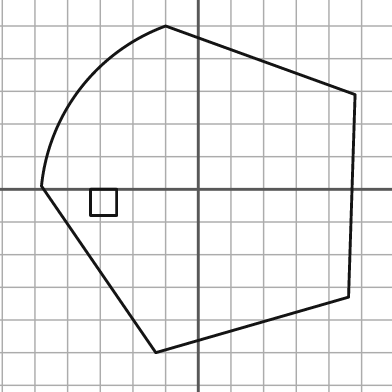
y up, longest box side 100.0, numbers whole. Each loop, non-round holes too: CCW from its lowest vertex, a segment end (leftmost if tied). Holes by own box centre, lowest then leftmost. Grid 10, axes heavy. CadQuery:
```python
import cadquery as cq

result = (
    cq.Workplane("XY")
    .moveTo(-13.0, -50.0)
    .lineTo(46.0, -33.0)
    .lineTo(48.0, 29.0)
    .lineTo(-10.0, 50.0)
    .threePointArc((-36.0, 31.0), (-48.0, 1.0))
    .close()
    .moveTo(-33.0, -8.0)
    .lineTo(-25.0, -8.0)
    .lineTo(-25.0, 0.0)
    .lineTo(-33.0, 0.0)
    .close()
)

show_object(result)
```